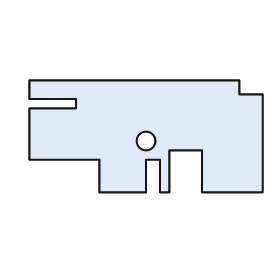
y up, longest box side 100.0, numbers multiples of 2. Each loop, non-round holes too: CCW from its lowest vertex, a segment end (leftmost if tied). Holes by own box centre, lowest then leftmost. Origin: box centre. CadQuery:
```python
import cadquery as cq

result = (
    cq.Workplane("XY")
    .moveTo(-20.0, -24.0)
    .lineTo(0.0, -24.0)
    .lineTo(0.0, -10.0)
    .lineTo(6.0, -10.0)
    .lineTo(6.0, -24.0)
    .lineTo(10.0, -24.0)
    .lineTo(10.0, -6.0)
    .lineTo(24.0, -6.0)
    .lineTo(24.0, -24.0)
    .lineTo(50.0, -24.0)
    .lineTo(50.0, 18.0)
    .lineTo(40.0, 18.0)
    .lineTo(40.0, 24.0)
    .lineTo(-50.0, 24.0)
    .lineTo(-50.0, 16.0)
    .lineTo(-30.0, 16.0)
    .lineTo(-30.0, 12.0)
    .lineTo(-50.0, 12.0)
    .lineTo(-50.0, -10.0)
    .lineTo(-20.0, -10.0)
    .close()
    .moveTo(0.0, -2.0)
    .circle(4.0)
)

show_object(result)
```